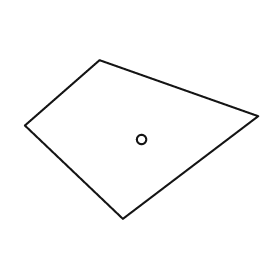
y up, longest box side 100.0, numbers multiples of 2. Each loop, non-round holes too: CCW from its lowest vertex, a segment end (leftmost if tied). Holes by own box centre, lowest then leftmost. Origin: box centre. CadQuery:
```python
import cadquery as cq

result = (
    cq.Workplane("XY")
    .moveTo(-8.0, -34.0)
    .lineTo(50.0, 10.0)
    .lineTo(-18.0, 34.0)
    .lineTo(-50.0, 6.0)
    .close()
    .moveTo(0.0, 0.0)
    .circle(2.0)
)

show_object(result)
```